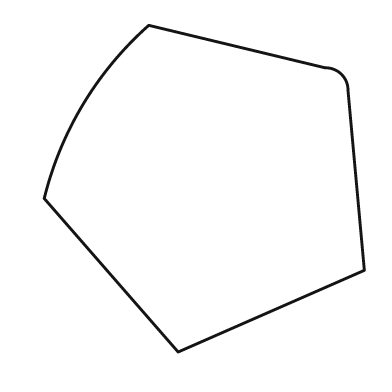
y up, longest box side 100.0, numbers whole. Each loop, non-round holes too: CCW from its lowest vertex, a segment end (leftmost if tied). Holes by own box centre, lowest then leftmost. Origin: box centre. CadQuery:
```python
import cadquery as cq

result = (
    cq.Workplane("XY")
    .moveTo(-8.0, -50.0)
    .lineTo(49.0, -25.0)
    .lineTo(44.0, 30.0)
    .threePointArc((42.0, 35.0), (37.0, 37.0))
    .lineTo(-17.0, 50.0)
    .threePointArc((-37.0, 26.0), (-49.0, -3.0))
    .close()
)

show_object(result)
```